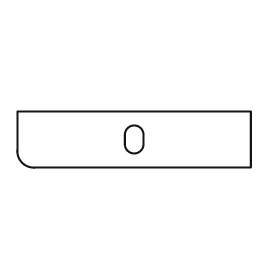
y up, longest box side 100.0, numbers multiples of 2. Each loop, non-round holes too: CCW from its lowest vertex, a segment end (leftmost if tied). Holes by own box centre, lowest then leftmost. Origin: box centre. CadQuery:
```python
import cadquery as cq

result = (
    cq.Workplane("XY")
    .moveTo(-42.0, -12.0)
    .lineTo(50.0, -12.0)
    .lineTo(50.0, 12.0)
    .lineTo(-50.0, 12.0)
    .lineTo(-50.0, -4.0)
    .threePointArc((-48.0, -10.0), (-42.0, -12.0))
    .close()
    .moveTo(-4.0, -2.0)
    .threePointArc((0.0, -6.0), (4.0, -2.0))
    .lineTo(4.0, 2.0)
    .threePointArc((0.0, 6.0), (-4.0, 2.0))
    .close()
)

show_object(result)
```